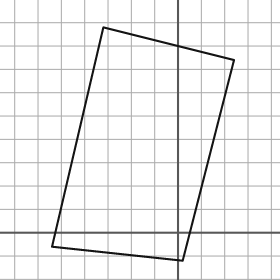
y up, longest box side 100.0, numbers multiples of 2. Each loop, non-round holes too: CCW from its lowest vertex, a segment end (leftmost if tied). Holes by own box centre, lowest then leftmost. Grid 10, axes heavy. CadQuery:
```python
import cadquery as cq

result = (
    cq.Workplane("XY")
    .moveTo(2.0, -12.0)
    .lineTo(24.0, 74.0)
    .lineTo(-32.0, 88.0)
    .lineTo(-54.0, -6.0)
    .close()
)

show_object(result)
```